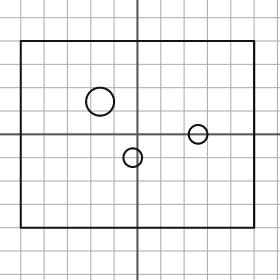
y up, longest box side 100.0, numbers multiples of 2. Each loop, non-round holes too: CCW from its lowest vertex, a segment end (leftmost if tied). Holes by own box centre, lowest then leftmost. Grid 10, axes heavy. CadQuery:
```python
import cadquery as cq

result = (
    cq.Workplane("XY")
    .moveTo(-50.0, -40.0)
    .lineTo(50.0, -40.0)
    .lineTo(50.0, 40.0)
    .lineTo(-50.0, 40.0)
    .close()
    .moveTo(-2.0, -10.0)
    .circle(4.0)
    .moveTo(26.0, 0.0)
    .circle(4.0)
    .moveTo(-16.0, 14.0)
    .circle(6.0)
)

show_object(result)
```